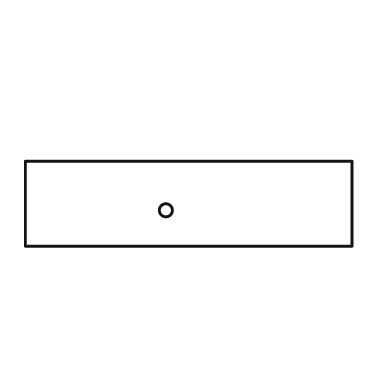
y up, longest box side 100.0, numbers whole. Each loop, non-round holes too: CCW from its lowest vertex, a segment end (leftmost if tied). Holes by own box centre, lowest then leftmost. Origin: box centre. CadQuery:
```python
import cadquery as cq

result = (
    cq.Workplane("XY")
    .moveTo(-50.0, -13.0)
    .lineTo(50.0, -13.0)
    .lineTo(50.0, 13.0)
    .lineTo(-50.0, 13.0)
    .close()
    .moveTo(-7.0, -2.0)
    .circle(2.0)
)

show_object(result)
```